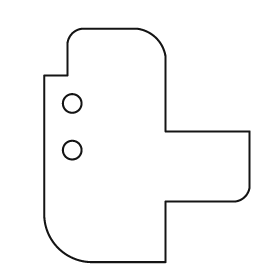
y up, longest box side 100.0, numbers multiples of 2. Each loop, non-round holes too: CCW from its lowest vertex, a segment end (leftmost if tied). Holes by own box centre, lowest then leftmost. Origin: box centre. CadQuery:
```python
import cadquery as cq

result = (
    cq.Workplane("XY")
    .moveTo(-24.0, -50.0)
    .lineTo(8.0, -50.0)
    .lineTo(8.0, -24.0)
    .lineTo(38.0, -24.0)
    .threePointArc((42.0, -22.0), (44.0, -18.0))
    .lineTo(44.0, 6.0)
    .lineTo(8.0, 6.0)
    .lineTo(8.0, 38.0)
    .threePointArc((4.0, 46.0), (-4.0, 50.0))
    .lineTo(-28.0, 50.0)
    .threePointArc((-32.0, 48.0), (-34.0, 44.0))
    .lineTo(-34.0, 30.0)
    .lineTo(-44.0, 30.0)
    .lineTo(-44.0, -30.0)
    .threePointArc((-38.0, -44.0), (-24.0, -50.0))
    .close()
    .moveTo(-32.0, -2.0)
    .circle(4.0)
    .moveTo(-32.0, 18.0)
    .circle(4.0)
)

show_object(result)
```